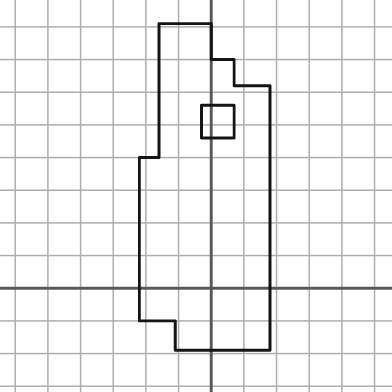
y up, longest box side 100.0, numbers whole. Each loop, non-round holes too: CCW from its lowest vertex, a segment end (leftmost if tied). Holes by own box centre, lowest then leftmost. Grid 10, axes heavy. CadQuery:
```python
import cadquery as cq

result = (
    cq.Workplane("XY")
    .moveTo(-11.0, -19.0)
    .lineTo(18.0, -19.0)
    .lineTo(18.0, 62.0)
    .lineTo(7.0, 62.0)
    .lineTo(7.0, 70.0)
    .lineTo(0.0, 70.0)
    .lineTo(0.0, 81.0)
    .lineTo(-16.0, 81.0)
    .lineTo(-16.0, 40.0)
    .lineTo(-22.0, 40.0)
    .lineTo(-22.0, -10.0)
    .lineTo(-11.0, -10.0)
    .close()
    .moveTo(-3.0, 46.0)
    .lineTo(7.0, 46.0)
    .lineTo(7.0, 56.0)
    .lineTo(-3.0, 56.0)
    .close()
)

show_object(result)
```